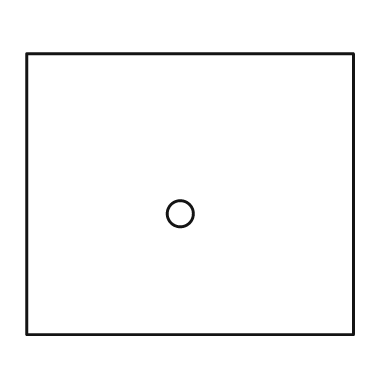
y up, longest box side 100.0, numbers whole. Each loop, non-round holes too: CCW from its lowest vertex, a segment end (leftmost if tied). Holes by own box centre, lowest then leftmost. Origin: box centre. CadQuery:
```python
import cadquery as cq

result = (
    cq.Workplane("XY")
    .moveTo(-50.0, -43.0)
    .lineTo(50.0, -43.0)
    .lineTo(50.0, 43.0)
    .lineTo(-50.0, 43.0)
    .close()
    .moveTo(-3.0, -6.0)
    .circle(4.0)
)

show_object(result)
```